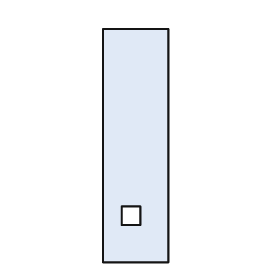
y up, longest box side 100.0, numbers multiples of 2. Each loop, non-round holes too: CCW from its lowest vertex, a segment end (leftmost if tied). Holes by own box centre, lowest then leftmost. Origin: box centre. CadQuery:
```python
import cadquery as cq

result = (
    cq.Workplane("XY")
    .moveTo(-14.0, -50.0)
    .lineTo(14.0, -50.0)
    .lineTo(14.0, 50.0)
    .lineTo(-14.0, 50.0)
    .close()
    .moveTo(-6.0, -34.0)
    .lineTo(2.0, -34.0)
    .lineTo(2.0, -26.0)
    .lineTo(-6.0, -26.0)
    .close()
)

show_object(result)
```